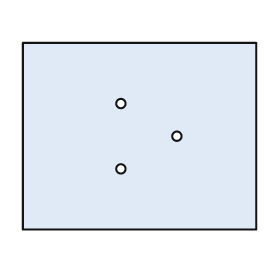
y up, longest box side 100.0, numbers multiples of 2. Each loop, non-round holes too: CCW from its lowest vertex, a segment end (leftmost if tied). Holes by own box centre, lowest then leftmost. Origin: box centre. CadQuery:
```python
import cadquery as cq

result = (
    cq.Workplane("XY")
    .moveTo(-50.0, -40.0)
    .lineTo(50.0, -40.0)
    .lineTo(50.0, 40.0)
    .lineTo(-50.0, 40.0)
    .close()
    .moveTo(-8.0, -14.0)
    .circle(2.0)
    .moveTo(16.0, 0.0)
    .circle(2.0)
    .moveTo(-8.0, 14.0)
    .circle(2.0)
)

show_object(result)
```